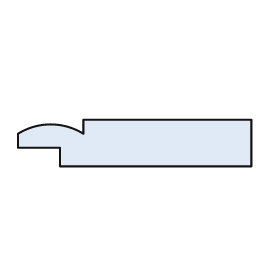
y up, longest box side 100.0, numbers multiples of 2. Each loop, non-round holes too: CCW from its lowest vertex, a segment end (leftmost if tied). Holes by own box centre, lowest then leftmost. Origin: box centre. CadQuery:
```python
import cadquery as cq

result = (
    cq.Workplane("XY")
    .moveTo(-32.0, -10.0)
    .lineTo(50.0, -10.0)
    .lineTo(50.0, 10.0)
    .lineTo(-22.0, 10.0)
    .lineTo(-22.0, 4.0)
    .threePointArc((-36.0, 8.0), (-50.0, 4.0))
    .lineTo(-50.0, -2.0)
    .lineTo(-32.0, -2.0)
    .close()
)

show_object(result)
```